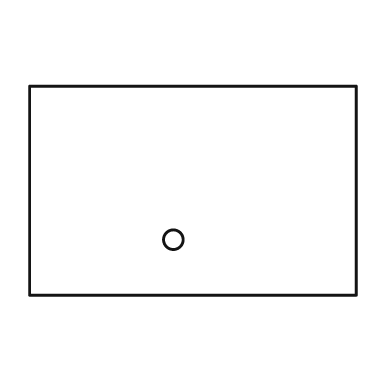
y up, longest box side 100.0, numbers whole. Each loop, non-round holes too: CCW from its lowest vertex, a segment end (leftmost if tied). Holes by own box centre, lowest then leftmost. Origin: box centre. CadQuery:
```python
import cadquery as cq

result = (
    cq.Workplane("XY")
    .moveTo(-50.0, -32.0)
    .lineTo(50.0, -32.0)
    .lineTo(50.0, 32.0)
    .lineTo(-50.0, 32.0)
    .close()
    .moveTo(-6.0, -15.0)
    .circle(3.0)
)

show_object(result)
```